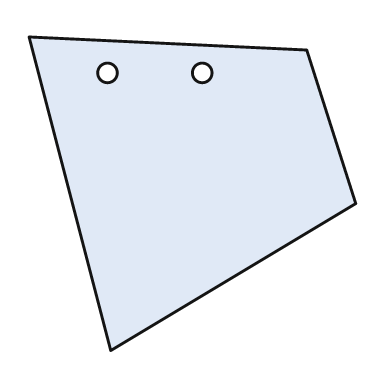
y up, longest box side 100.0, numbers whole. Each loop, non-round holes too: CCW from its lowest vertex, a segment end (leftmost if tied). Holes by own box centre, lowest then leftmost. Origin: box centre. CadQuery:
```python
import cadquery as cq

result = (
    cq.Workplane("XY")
    .moveTo(-25.0, -48.0)
    .lineTo(50.0, -3.0)
    .lineTo(35.0, 44.0)
    .lineTo(-50.0, 48.0)
    .close()
    .moveTo(-26.0, 37.0)
    .circle(3.0)
    .moveTo(3.0, 37.0)
    .circle(3.0)
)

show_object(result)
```